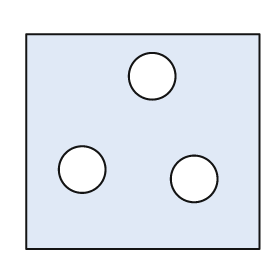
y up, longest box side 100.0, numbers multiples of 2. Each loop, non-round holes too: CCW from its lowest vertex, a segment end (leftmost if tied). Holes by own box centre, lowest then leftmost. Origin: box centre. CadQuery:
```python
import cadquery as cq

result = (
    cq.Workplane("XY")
    .moveTo(-50.0, -46.0)
    .lineTo(50.0, -46.0)
    .lineTo(50.0, 46.0)
    .lineTo(-50.0, 46.0)
    .close()
    .moveTo(22.0, -16.0)
    .circle(10.0)
    .moveTo(-26.0, -12.0)
    .circle(10.0)
    .moveTo(4.0, 28.0)
    .circle(10.0)
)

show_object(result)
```